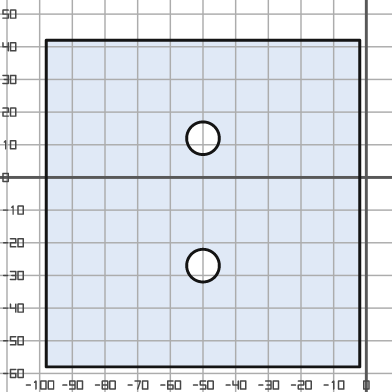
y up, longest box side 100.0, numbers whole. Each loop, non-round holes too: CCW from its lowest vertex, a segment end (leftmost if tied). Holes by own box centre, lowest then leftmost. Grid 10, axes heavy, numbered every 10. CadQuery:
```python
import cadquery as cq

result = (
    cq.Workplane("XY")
    .moveTo(-98.0, -58.0)
    .lineTo(-2.0, -58.0)
    .lineTo(-2.0, 42.0)
    .lineTo(-98.0, 42.0)
    .close()
    .moveTo(-50.0, -27.0)
    .circle(5.0)
    .moveTo(-50.0, 12.0)
    .circle(5.0)
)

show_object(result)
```